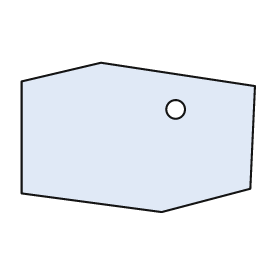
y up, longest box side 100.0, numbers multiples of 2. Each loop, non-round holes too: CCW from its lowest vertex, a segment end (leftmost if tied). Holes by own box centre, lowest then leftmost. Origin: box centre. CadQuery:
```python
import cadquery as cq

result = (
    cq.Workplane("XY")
    .moveTo(10.0, -32.0)
    .lineTo(48.0, -22.0)
    .lineTo(50.0, 22.0)
    .lineTo(-16.0, 32.0)
    .lineTo(-50.0, 24.0)
    .lineTo(-50.0, -24.0)
    .close()
    .moveTo(16.0, 12.0)
    .circle(4.0)
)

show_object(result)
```